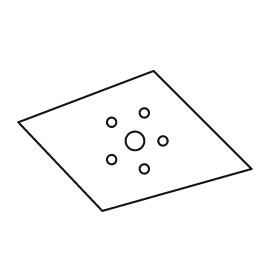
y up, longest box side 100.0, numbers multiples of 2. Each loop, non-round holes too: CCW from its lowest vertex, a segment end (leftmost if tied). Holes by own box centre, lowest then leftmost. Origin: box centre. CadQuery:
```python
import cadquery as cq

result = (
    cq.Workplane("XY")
    .moveTo(-14.0, -30.0)
    .lineTo(50.0, -12.0)
    .lineTo(8.0, 30.0)
    .lineTo(-50.0, 8.0)
    .close()
    .moveTo(4.0, -12.0)
    .circle(2.0)
    .moveTo(-10.0, -8.0)
    .circle(2.0)
    .moveTo(0.0, 0.0)
    .circle(4.0)
    .moveTo(12.0, 0.0)
    .circle(2.0)
    .moveTo(-10.0, 8.0)
    .circle(2.0)
    .moveTo(4.0, 12.0)
    .circle(2.0)
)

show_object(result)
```